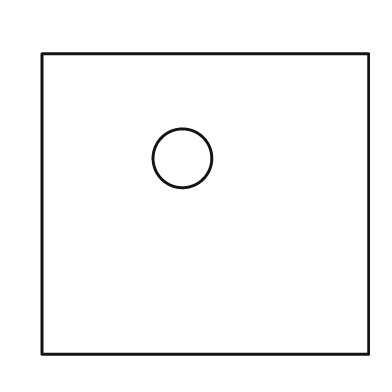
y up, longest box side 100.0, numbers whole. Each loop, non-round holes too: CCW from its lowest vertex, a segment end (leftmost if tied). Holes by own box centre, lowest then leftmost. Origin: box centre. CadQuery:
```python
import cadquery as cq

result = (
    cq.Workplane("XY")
    .moveTo(-50.0, -46.0)
    .lineTo(50.0, -46.0)
    .lineTo(50.0, 46.0)
    .lineTo(-50.0, 46.0)
    .close()
    .moveTo(-7.0, 14.0)
    .circle(9.0)
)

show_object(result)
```